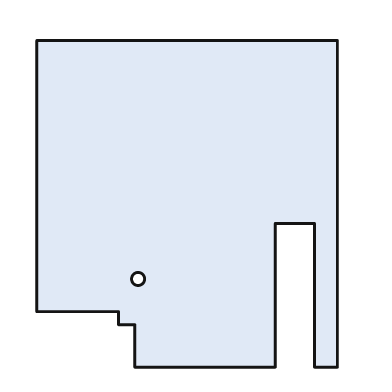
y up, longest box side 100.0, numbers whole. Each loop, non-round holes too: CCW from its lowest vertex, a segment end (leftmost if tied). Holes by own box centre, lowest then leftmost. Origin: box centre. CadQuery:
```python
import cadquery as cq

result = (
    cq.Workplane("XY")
    .moveTo(-16.0, -50.0)
    .lineTo(27.0, -50.0)
    .lineTo(27.0, -6.0)
    .lineTo(39.0, -6.0)
    .lineTo(39.0, -50.0)
    .lineTo(46.0, -50.0)
    .lineTo(46.0, 50.0)
    .lineTo(-46.0, 50.0)
    .lineTo(-46.0, -33.0)
    .lineTo(-21.0, -33.0)
    .lineTo(-21.0, -37.0)
    .lineTo(-16.0, -37.0)
    .close()
    .moveTo(-15.0, -23.0)
    .circle(2.0)
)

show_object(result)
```